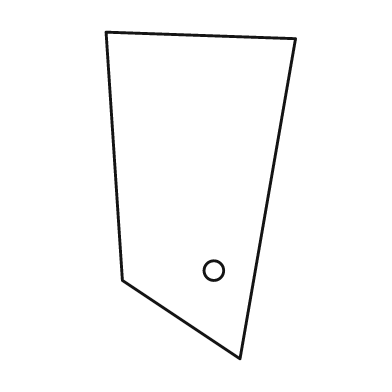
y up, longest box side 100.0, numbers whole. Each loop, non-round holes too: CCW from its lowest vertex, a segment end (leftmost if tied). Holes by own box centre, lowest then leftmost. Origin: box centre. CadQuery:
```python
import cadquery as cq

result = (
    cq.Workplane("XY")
    .moveTo(12.0, -50.0)
    .lineTo(29.0, 48.0)
    .lineTo(-29.0, 50.0)
    .lineTo(-24.0, -26.0)
    .close()
    .moveTo(4.0, -23.0)
    .circle(3.0)
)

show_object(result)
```